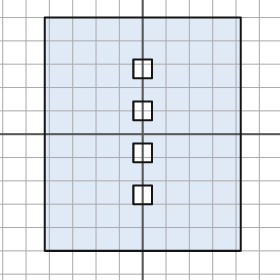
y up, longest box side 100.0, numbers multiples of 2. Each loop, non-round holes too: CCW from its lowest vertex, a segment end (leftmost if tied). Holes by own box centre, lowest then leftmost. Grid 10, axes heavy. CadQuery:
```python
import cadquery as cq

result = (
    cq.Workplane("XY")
    .moveTo(-42.0, -50.0)
    .lineTo(42.0, -50.0)
    .lineTo(42.0, 50.0)
    .lineTo(-42.0, 50.0)
    .close()
    .moveTo(-4.0, -30.0)
    .lineTo(4.0, -30.0)
    .lineTo(4.0, -22.0)
    .lineTo(-4.0, -22.0)
    .close()
    .moveTo(-4.0, -12.0)
    .lineTo(4.0, -12.0)
    .lineTo(4.0, -4.0)
    .lineTo(-4.0, -4.0)
    .close()
    .moveTo(-4.0, 6.0)
    .lineTo(4.0, 6.0)
    .lineTo(4.0, 14.0)
    .lineTo(-4.0, 14.0)
    .close()
    .moveTo(-4.0, 24.0)
    .lineTo(4.0, 24.0)
    .lineTo(4.0, 32.0)
    .lineTo(-4.0, 32.0)
    .close()
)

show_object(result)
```